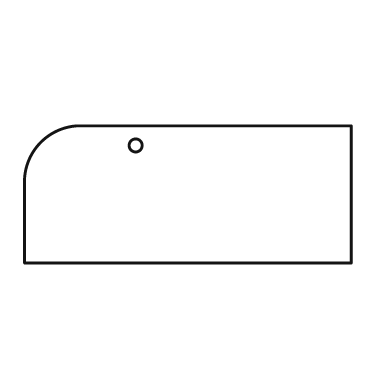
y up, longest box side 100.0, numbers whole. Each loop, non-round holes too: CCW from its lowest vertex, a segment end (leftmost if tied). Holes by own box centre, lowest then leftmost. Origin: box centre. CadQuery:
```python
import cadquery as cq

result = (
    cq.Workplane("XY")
    .moveTo(-50.0, -21.0)
    .lineTo(50.0, -21.0)
    .lineTo(50.0, 21.0)
    .lineTo(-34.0, 21.0)
    .threePointArc((-45.0, 16.0), (-50.0, 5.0))
    .close()
    .moveTo(-16.0, 15.0)
    .circle(2.0)
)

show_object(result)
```